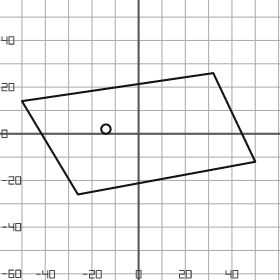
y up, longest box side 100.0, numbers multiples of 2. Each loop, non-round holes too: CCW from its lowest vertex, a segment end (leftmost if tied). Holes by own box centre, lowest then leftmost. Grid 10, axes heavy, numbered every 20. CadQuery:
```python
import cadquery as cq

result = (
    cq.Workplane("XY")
    .moveTo(-26.0, -26.0)
    .lineTo(50.0, -12.0)
    .lineTo(32.0, 26.0)
    .lineTo(-50.0, 14.0)
    .close()
    .moveTo(-14.0, 2.0)
    .circle(2.0)
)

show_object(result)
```